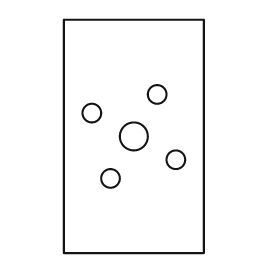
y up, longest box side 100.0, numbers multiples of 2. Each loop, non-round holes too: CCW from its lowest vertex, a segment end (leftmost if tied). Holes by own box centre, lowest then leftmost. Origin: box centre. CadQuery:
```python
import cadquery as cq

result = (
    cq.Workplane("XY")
    .moveTo(-30.0, -50.0)
    .lineTo(30.0, -50.0)
    .lineTo(30.0, 50.0)
    .lineTo(-30.0, 50.0)
    .close()
    .moveTo(-10.0, -18.0)
    .circle(4.0)
    .moveTo(18.0, -10.0)
    .circle(4.0)
    .moveTo(0.0, 0.0)
    .circle(6.0)
    .moveTo(-18.0, 10.0)
    .circle(4.0)
    .moveTo(10.0, 18.0)
    .circle(4.0)
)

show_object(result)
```